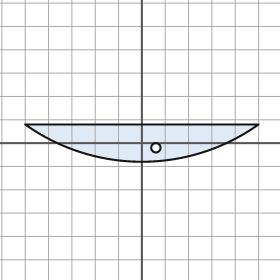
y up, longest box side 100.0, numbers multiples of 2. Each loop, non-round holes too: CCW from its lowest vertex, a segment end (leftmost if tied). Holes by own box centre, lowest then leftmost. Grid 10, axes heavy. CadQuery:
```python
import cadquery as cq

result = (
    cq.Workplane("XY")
    .moveTo(-50.0, 8.0)
    .threePointArc((0.0, -8.0), (50.0, 8.0))
    .close()
    .moveTo(6.0, -2.0)
    .circle(2.0)
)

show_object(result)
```